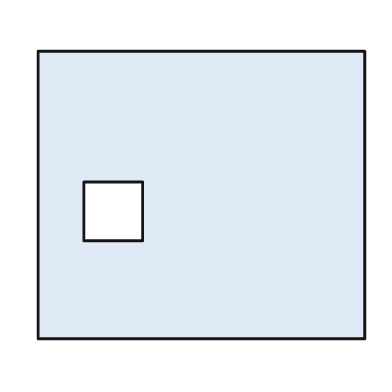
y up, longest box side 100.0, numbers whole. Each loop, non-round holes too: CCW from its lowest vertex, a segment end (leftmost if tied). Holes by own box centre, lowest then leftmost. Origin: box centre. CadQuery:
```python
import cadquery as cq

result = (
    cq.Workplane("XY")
    .moveTo(-50.0, -44.0)
    .lineTo(50.0, -44.0)
    .lineTo(50.0, 44.0)
    .lineTo(-50.0, 44.0)
    .close()
    .moveTo(-36.0, -14.0)
    .lineTo(-18.0, -14.0)
    .lineTo(-18.0, 4.0)
    .lineTo(-36.0, 4.0)
    .close()
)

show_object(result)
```